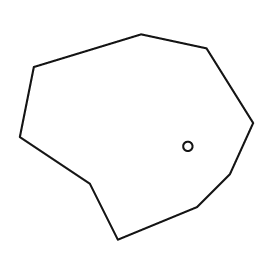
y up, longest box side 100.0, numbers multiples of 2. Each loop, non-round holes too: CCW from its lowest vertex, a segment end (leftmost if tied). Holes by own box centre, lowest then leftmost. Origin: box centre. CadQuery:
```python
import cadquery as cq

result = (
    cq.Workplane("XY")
    .moveTo(-8.0, -44.0)
    .lineTo(26.0, -30.0)
    .lineTo(40.0, -16.0)
    .lineTo(50.0, 6.0)
    .lineTo(30.0, 38.0)
    .lineTo(2.0, 44.0)
    .lineTo(-44.0, 30.0)
    .lineTo(-50.0, 0.0)
    .lineTo(-20.0, -20.0)
    .close()
    .moveTo(22.0, -4.0)
    .circle(2.0)
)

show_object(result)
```